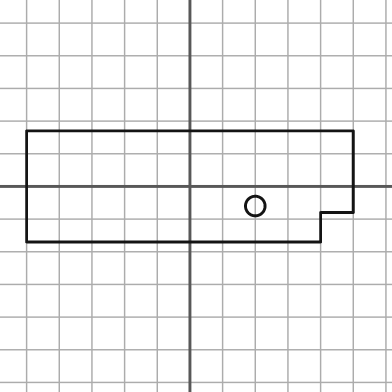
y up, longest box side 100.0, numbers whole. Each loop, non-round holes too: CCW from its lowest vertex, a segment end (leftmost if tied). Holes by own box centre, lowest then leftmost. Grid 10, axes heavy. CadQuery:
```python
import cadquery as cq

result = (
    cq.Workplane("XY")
    .moveTo(-50.0, -17.0)
    .lineTo(40.0, -17.0)
    .lineTo(40.0, -8.0)
    .lineTo(50.0, -8.0)
    .lineTo(50.0, 17.0)
    .lineTo(-50.0, 17.0)
    .close()
    .moveTo(20.0, -6.0)
    .circle(3.0)
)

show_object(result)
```